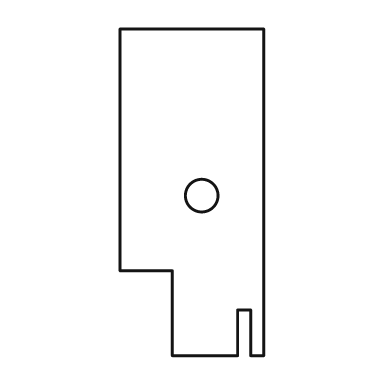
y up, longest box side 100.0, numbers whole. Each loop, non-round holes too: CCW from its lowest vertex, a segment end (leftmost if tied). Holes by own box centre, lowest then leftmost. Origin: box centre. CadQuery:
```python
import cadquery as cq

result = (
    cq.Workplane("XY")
    .moveTo(-6.0, -50.0)
    .lineTo(14.0, -50.0)
    .lineTo(14.0, -36.0)
    .lineTo(18.0, -36.0)
    .lineTo(18.0, -50.0)
    .lineTo(22.0, -50.0)
    .lineTo(22.0, 50.0)
    .lineTo(-22.0, 50.0)
    .lineTo(-22.0, -24.0)
    .lineTo(-6.0, -24.0)
    .close()
    .moveTo(3.0, -1.0)
    .circle(5.0)
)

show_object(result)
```